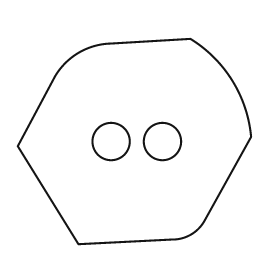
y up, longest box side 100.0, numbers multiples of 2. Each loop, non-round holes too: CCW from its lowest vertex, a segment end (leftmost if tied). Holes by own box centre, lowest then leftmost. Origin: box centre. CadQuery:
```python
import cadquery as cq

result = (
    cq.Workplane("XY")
    .moveTo(-24.0, -44.0)
    .lineTo(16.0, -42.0)
    .threePointArc((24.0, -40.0), (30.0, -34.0))
    .lineTo(50.0, 2.0)
    .threePointArc((42.0, 26.0), (24.0, 44.0))
    .lineTo(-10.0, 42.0)
    .threePointArc((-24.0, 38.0), (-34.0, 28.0))
    .lineTo(-50.0, -2.0)
    .close()
    .moveTo(-10.0, 0.0)
    .circle(8.0)
    .moveTo(12.0, 0.0)
    .circle(8.0)
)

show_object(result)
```